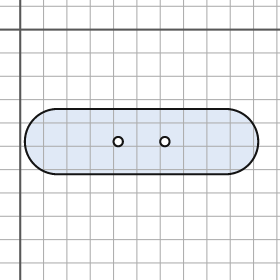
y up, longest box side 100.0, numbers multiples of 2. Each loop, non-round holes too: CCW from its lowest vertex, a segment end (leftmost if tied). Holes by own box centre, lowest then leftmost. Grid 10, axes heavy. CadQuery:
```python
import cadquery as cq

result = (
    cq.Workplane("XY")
    .moveTo(16.0, -62.0)
    .lineTo(88.0, -62.0)
    .threePointArc((102.0, -48.0), (88.0, -34.0))
    .lineTo(16.0, -34.0)
    .threePointArc((2.0, -48.0), (16.0, -62.0))
    .close()
    .moveTo(42.0, -48.0)
    .circle(2.0)
    .moveTo(62.0, -48.0)
    .circle(2.0)
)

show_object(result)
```